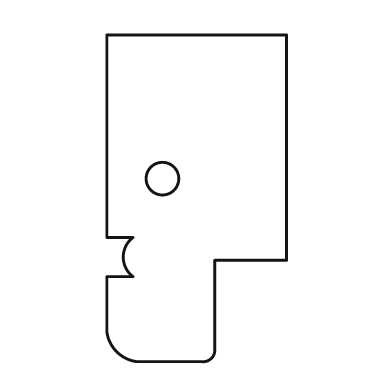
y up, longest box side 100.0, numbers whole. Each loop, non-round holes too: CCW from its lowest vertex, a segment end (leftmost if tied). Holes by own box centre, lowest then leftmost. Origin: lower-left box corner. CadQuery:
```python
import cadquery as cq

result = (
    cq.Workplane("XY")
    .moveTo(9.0, 0.0)
    .lineTo(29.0, 0.0)
    .threePointArc((32.0, 1.0), (33.0, 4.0))
    .lineTo(33.0, 31.0)
    .lineTo(55.0, 31.0)
    .lineTo(55.0, 100.0)
    .lineTo(0.0, 100.0)
    .lineTo(0.0, 38.0)
    .lineTo(8.0, 38.0)
    .threePointArc((5.0, 32.0), (8.0, 26.0))
    .lineTo(0.0, 26.0)
    .lineTo(0.0, 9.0)
    .threePointArc((3.0, 3.0), (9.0, 0.0))
    .close()
    .moveTo(17.0, 56.0)
    .circle(5.0)
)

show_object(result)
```